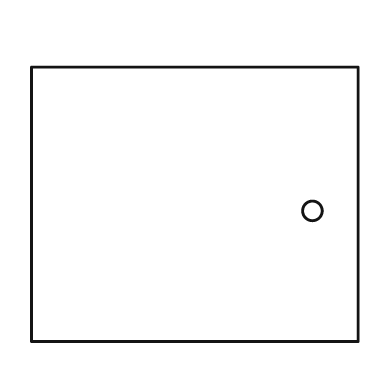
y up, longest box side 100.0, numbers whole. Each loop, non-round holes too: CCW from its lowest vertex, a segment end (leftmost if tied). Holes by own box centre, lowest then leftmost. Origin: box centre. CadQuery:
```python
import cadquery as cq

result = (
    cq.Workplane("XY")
    .moveTo(-50.0, -42.0)
    .lineTo(50.0, -42.0)
    .lineTo(50.0, 42.0)
    .lineTo(-50.0, 42.0)
    .close()
    .moveTo(36.0, -2.0)
    .circle(3.0)
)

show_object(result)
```